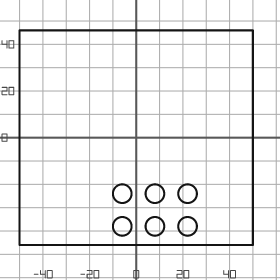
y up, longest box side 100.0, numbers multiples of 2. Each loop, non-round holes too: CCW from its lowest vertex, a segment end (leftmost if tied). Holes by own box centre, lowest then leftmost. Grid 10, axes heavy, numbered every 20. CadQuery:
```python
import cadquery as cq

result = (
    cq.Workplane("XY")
    .moveTo(-50.0, -46.0)
    .lineTo(50.0, -46.0)
    .lineTo(50.0, 46.0)
    .lineTo(-50.0, 46.0)
    .close()
    .moveTo(-6.0, -38.0)
    .circle(4.0)
    .moveTo(8.0, -38.0)
    .circle(4.0)
    .moveTo(22.0, -38.0)
    .circle(4.0)
    .moveTo(-6.0, -24.0)
    .circle(4.0)
    .moveTo(8.0, -24.0)
    .circle(4.0)
    .moveTo(22.0, -24.0)
    .circle(4.0)
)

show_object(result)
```